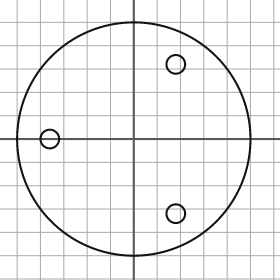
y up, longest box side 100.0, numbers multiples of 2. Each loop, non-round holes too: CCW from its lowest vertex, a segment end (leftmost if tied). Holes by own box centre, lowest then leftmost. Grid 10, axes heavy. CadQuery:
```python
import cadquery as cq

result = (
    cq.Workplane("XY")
    .moveTo(0.0, 0.0)
    .circle(50.0)
    .moveTo(18.0, -32.0)
    .circle(4.0)
    .moveTo(-36.0, 0.0)
    .circle(4.0)
    .moveTo(18.0, 32.0)
    .circle(4.0)
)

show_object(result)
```